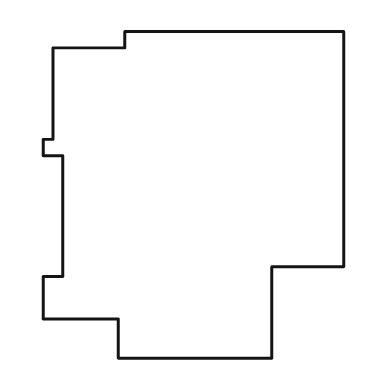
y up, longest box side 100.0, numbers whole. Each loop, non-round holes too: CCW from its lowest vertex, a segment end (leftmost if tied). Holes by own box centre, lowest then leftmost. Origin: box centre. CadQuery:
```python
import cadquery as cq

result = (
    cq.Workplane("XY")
    .moveTo(-23.0, -50.0)
    .lineTo(24.0, -50.0)
    .lineTo(24.0, -22.0)
    .lineTo(46.0, -22.0)
    .lineTo(46.0, 50.0)
    .lineTo(-21.0, 50.0)
    .lineTo(-21.0, 45.0)
    .lineTo(-43.0, 45.0)
    .lineTo(-43.0, 17.0)
    .lineTo(-46.0, 17.0)
    .lineTo(-46.0, 12.0)
    .lineTo(-40.0, 12.0)
    .lineTo(-40.0, -25.0)
    .lineTo(-46.0, -25.0)
    .lineTo(-46.0, -38.0)
    .lineTo(-23.0, -38.0)
    .close()
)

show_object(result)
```